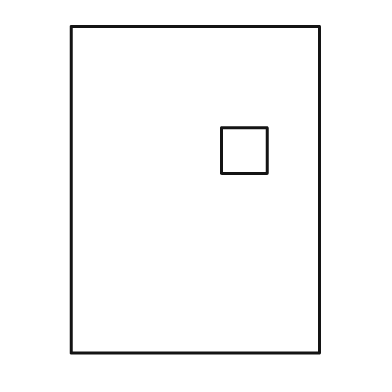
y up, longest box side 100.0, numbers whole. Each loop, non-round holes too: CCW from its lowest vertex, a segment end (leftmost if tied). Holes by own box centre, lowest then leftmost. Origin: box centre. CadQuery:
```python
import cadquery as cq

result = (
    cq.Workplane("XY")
    .moveTo(-38.0, -50.0)
    .lineTo(38.0, -50.0)
    .lineTo(38.0, 50.0)
    .lineTo(-38.0, 50.0)
    .close()
    .moveTo(8.0, 5.0)
    .lineTo(22.0, 5.0)
    .lineTo(22.0, 19.0)
    .lineTo(8.0, 19.0)
    .close()
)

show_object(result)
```